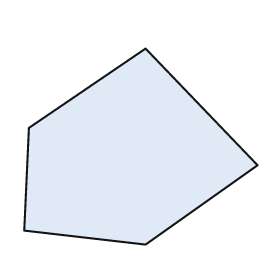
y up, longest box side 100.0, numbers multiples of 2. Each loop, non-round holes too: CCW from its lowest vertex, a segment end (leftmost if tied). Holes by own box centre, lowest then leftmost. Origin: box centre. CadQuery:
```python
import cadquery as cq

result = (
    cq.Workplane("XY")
    .moveTo(2.0, -42.0)
    .lineTo(50.0, -8.0)
    .lineTo(2.0, 42.0)
    .lineTo(-48.0, 8.0)
    .lineTo(-50.0, -36.0)
    .close()
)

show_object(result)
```